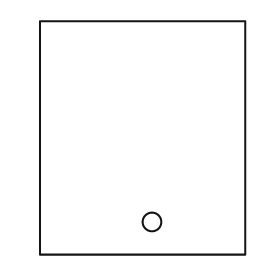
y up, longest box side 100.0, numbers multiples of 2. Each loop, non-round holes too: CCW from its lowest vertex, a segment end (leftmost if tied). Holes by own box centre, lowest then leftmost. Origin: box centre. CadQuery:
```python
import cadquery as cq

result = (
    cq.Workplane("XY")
    .moveTo(-44.0, -50.0)
    .lineTo(44.0, -50.0)
    .lineTo(44.0, 50.0)
    .lineTo(-44.0, 50.0)
    .close()
    .moveTo(4.0, -36.0)
    .circle(4.0)
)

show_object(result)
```